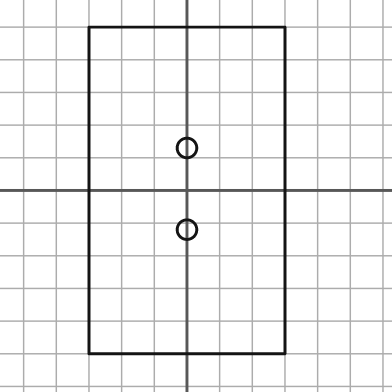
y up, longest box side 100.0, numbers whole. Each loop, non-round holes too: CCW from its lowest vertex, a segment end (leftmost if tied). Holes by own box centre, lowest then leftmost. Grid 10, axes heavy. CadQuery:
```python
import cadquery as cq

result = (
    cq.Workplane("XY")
    .moveTo(-30.0, -50.0)
    .lineTo(30.0, -50.0)
    .lineTo(30.0, 50.0)
    .lineTo(-30.0, 50.0)
    .close()
    .moveTo(0.0, -12.0)
    .circle(3.0)
    .moveTo(0.0, 13.0)
    .circle(3.0)
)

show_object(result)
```